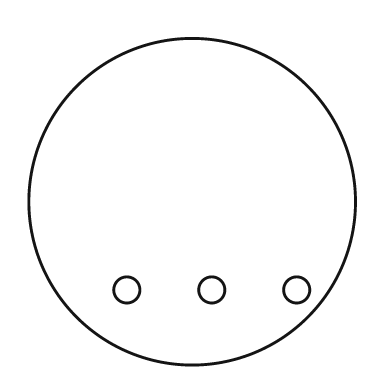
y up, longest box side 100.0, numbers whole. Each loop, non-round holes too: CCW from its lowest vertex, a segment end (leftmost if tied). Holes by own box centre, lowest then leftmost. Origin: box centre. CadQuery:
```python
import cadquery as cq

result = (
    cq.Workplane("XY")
    .moveTo(0.0, 0.0)
    .circle(50.0)
    .moveTo(-20.0, -27.0)
    .circle(4.0)
    .moveTo(6.0, -27.0)
    .circle(4.0)
    .moveTo(32.0, -27.0)
    .circle(4.0)
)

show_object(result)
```